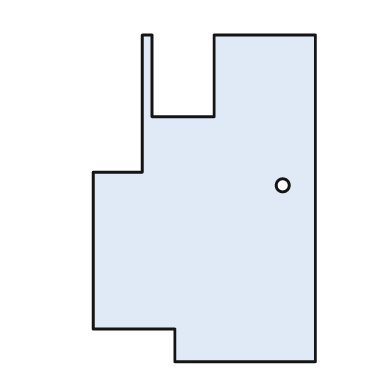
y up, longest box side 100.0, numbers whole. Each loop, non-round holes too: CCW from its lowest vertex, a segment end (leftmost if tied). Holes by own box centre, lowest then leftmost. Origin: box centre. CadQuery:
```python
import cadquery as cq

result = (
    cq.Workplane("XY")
    .moveTo(-9.0, -50.0)
    .lineTo(34.0, -50.0)
    .lineTo(34.0, 50.0)
    .lineTo(3.0, 50.0)
    .lineTo(3.0, 25.0)
    .lineTo(-16.0, 25.0)
    .lineTo(-16.0, 50.0)
    .lineTo(-19.0, 50.0)
    .lineTo(-19.0, 8.0)
    .lineTo(-34.0, 8.0)
    .lineTo(-34.0, -40.0)
    .lineTo(-9.0, -40.0)
    .close()
    .moveTo(24.0, 4.0)
    .circle(2.0)
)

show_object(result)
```